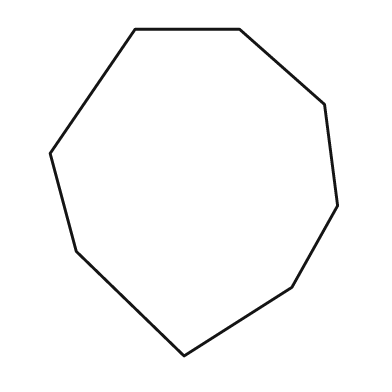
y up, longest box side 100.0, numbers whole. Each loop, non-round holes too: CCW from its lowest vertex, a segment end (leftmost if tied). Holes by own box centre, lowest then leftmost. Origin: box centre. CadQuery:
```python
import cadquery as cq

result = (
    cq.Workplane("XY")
    .moveTo(-3.0, -50.0)
    .lineTo(30.0, -29.0)
    .lineTo(44.0, -4.0)
    .lineTo(40.0, 27.0)
    .lineTo(14.0, 50.0)
    .lineTo(-18.0, 50.0)
    .lineTo(-44.0, 12.0)
    .lineTo(-36.0, -18.0)
    .close()
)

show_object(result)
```